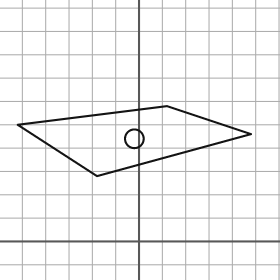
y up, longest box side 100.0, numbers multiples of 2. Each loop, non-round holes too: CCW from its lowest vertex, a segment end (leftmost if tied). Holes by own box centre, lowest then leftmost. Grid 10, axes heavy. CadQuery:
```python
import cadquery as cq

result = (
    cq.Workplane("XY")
    .moveTo(-18.0, 28.0)
    .lineTo(48.0, 46.0)
    .lineTo(12.0, 58.0)
    .lineTo(-52.0, 50.0)
    .close()
    .moveTo(-2.0, 44.0)
    .circle(4.0)
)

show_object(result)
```